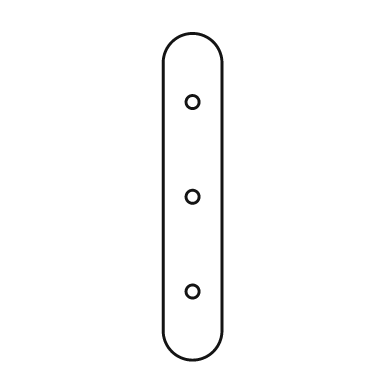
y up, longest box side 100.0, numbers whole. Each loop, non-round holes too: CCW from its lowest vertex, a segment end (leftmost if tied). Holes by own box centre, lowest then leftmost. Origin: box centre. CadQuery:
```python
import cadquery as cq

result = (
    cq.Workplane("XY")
    .moveTo(-9.0, -41.0)
    .threePointArc((0.0, -50.0), (9.0, -41.0))
    .lineTo(9.0, 41.0)
    .threePointArc((0.0, 50.0), (-9.0, 41.0))
    .close()
    .moveTo(0.0, -29.0)
    .circle(2.0)
    .moveTo(0.0, 0.0)
    .circle(2.0)
    .moveTo(0.0, 29.0)
    .circle(2.0)
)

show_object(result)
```